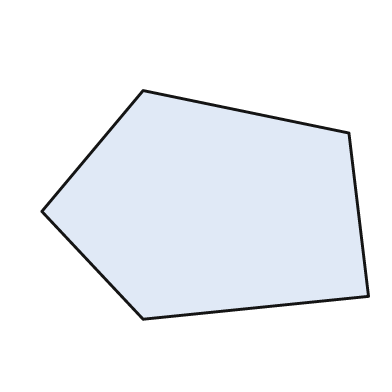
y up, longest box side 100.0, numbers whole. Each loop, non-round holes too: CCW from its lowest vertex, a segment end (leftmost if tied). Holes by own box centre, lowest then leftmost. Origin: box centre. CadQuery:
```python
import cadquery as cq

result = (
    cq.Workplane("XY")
    .moveTo(-19.0, -35.0)
    .lineTo(50.0, -28.0)
    .lineTo(44.0, 22.0)
    .lineTo(-19.0, 35.0)
    .lineTo(-50.0, -2.0)
    .close()
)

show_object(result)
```